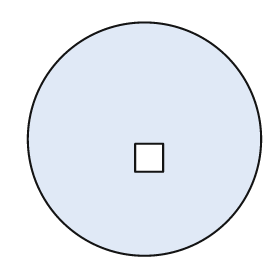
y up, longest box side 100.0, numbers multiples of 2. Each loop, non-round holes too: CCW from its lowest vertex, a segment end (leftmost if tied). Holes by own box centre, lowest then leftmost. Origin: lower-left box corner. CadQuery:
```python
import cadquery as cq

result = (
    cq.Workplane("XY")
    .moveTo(50.0, 50.0)
    .circle(50.0)
    .moveTo(46.0, 36.0)
    .lineTo(58.0, 36.0)
    .lineTo(58.0, 48.0)
    .lineTo(46.0, 48.0)
    .close()
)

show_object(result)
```